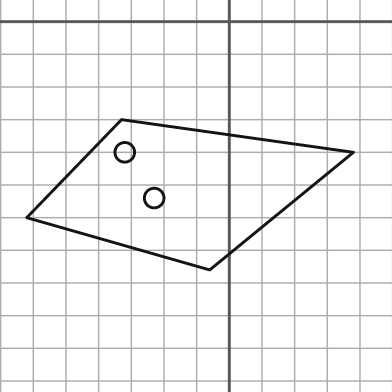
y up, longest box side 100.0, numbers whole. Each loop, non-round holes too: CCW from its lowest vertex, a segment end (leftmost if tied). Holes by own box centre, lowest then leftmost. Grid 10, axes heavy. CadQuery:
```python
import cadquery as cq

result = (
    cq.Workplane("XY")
    .moveTo(-6.0, -76.0)
    .lineTo(38.0, -40.0)
    .lineTo(-33.0, -30.0)
    .lineTo(-62.0, -60.0)
    .close()
    .moveTo(-23.0, -54.0)
    .circle(3.0)
    .moveTo(-32.0, -40.0)
    .circle(3.0)
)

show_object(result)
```